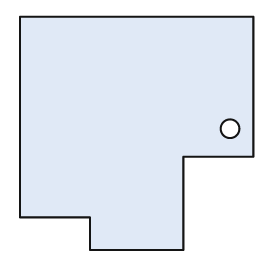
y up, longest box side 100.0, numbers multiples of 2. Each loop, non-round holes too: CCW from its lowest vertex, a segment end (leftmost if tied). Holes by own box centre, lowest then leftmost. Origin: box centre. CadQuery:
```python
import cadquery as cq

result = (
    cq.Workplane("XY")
    .moveTo(-20.0, -50.0)
    .lineTo(20.0, -50.0)
    .lineTo(20.0, -10.0)
    .lineTo(50.0, -10.0)
    .lineTo(50.0, 50.0)
    .lineTo(-50.0, 50.0)
    .lineTo(-50.0, -36.0)
    .lineTo(-20.0, -36.0)
    .close()
    .moveTo(40.0, 2.0)
    .circle(4.0)
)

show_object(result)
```